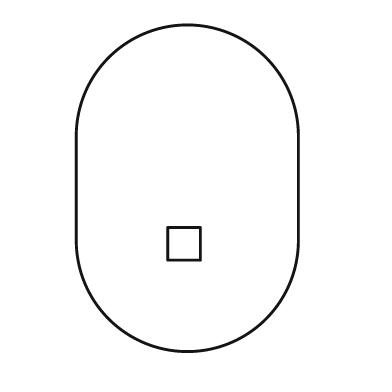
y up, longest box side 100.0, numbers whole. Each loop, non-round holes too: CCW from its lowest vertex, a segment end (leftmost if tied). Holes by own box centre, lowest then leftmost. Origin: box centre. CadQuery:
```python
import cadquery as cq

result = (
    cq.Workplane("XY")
    .moveTo(-34.0, -16.0)
    .threePointArc((0.0, -50.0), (34.0, -16.0))
    .lineTo(34.0, 16.0)
    .threePointArc((0.0, 50.0), (-34.0, 16.0))
    .close()
    .moveTo(-6.0, -22.0)
    .lineTo(4.0, -22.0)
    .lineTo(4.0, -12.0)
    .lineTo(-6.0, -12.0)
    .close()
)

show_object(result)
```